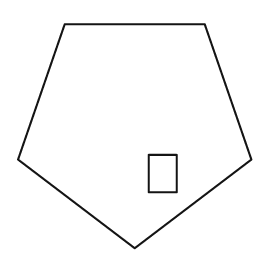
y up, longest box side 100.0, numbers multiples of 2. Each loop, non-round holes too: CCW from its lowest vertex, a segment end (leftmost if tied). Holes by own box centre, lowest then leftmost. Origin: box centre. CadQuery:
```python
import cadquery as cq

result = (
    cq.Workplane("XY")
    .moveTo(0.0, -48.0)
    .lineTo(50.0, -10.0)
    .lineTo(30.0, 48.0)
    .lineTo(-30.0, 48.0)
    .lineTo(-50.0, -10.0)
    .close()
    .moveTo(6.0, -24.0)
    .lineTo(18.0, -24.0)
    .lineTo(18.0, -8.0)
    .lineTo(6.0, -8.0)
    .close()
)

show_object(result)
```